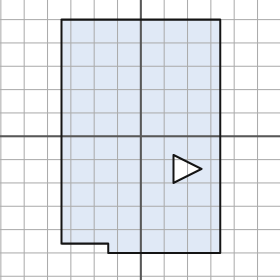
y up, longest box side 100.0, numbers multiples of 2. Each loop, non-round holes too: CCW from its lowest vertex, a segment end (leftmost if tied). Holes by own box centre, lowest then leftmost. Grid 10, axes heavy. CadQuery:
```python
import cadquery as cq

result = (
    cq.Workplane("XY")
    .moveTo(-14.0, -50.0)
    .lineTo(34.0, -50.0)
    .lineTo(34.0, 50.0)
    .lineTo(-34.0, 50.0)
    .lineTo(-34.0, -46.0)
    .lineTo(-14.0, -46.0)
    .close()
    .moveTo(14.0, -20.0)
    .lineTo(26.0, -14.0)
    .lineTo(14.0, -8.0)
    .close()
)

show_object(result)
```